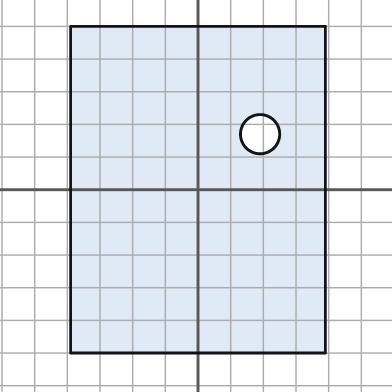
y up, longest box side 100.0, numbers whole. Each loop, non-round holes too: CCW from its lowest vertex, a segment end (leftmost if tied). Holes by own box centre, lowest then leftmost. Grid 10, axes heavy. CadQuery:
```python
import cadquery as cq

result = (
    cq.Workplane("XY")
    .moveTo(-39.0, -50.0)
    .lineTo(39.0, -50.0)
    .lineTo(39.0, 50.0)
    .lineTo(-39.0, 50.0)
    .close()
    .moveTo(19.0, 17.0)
    .circle(6.0)
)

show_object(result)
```